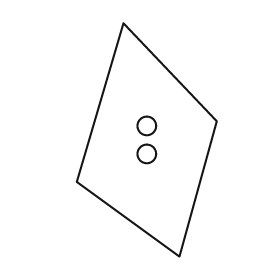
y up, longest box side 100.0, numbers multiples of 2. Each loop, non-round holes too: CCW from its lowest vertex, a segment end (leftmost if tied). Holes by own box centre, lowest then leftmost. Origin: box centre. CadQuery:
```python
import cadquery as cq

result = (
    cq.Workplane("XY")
    .moveTo(14.0, -50.0)
    .lineTo(30.0, 8.0)
    .lineTo(-10.0, 50.0)
    .lineTo(-30.0, -18.0)
    .close()
    .moveTo(0.0, -6.0)
    .circle(4.0)
    .moveTo(0.0, 6.0)
    .circle(4.0)
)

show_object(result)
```